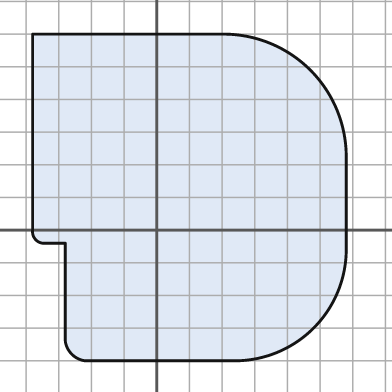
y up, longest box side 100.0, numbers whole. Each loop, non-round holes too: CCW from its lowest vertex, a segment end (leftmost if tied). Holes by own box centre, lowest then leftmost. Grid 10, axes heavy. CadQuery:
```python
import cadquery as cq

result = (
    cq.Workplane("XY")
    .moveTo(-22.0, -40.0)
    .lineTo(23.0, -40.0)
    .threePointArc((48.0, -30.0), (58.0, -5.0))
    .lineTo(58.0, 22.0)
    .threePointArc((47.0, 49.0), (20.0, 60.0))
    .lineTo(-38.0, 60.0)
    .lineTo(-38.0, 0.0)
    .threePointArc((-37.0, -3.0), (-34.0, -4.0))
    .lineTo(-28.0, -4.0)
    .lineTo(-28.0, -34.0)
    .threePointArc((-26.0, -38.0), (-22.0, -40.0))
    .close()
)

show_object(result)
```